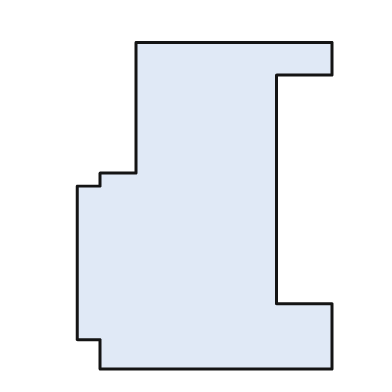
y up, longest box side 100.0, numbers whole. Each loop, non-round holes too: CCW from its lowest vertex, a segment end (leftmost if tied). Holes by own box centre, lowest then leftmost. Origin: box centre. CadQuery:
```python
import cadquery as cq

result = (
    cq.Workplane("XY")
    .moveTo(-32.0, -50.0)
    .lineTo(39.0, -50.0)
    .lineTo(39.0, -30.0)
    .lineTo(22.0, -30.0)
    .lineTo(22.0, 40.0)
    .lineTo(39.0, 40.0)
    .lineTo(39.0, 50.0)
    .lineTo(-21.0, 50.0)
    .lineTo(-21.0, 10.0)
    .lineTo(-32.0, 10.0)
    .lineTo(-32.0, 6.0)
    .lineTo(-39.0, 6.0)
    .lineTo(-39.0, -41.0)
    .lineTo(-32.0, -41.0)
    .close()
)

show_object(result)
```